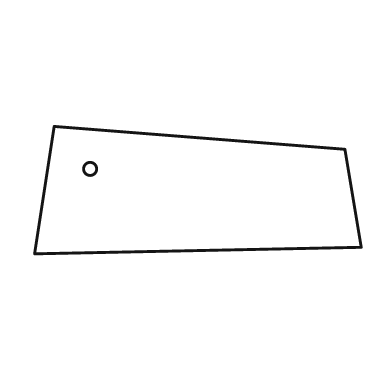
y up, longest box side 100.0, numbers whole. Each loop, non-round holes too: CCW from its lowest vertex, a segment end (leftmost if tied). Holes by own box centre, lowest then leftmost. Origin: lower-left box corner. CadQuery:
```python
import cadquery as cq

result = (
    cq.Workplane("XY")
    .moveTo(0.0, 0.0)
    .lineTo(100.0, 2.0)
    .lineTo(95.0, 32.0)
    .lineTo(6.0, 39.0)
    .close()
    .moveTo(17.0, 26.0)
    .circle(2.0)
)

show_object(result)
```